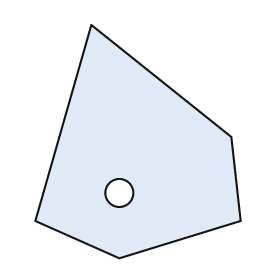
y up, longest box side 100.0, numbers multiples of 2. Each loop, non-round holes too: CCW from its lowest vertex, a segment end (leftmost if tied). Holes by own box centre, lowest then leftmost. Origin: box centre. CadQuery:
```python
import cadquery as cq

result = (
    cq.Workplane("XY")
    .moveTo(-8.0, -50.0)
    .lineTo(44.0, -34.0)
    .lineTo(40.0, 2.0)
    .lineTo(-20.0, 50.0)
    .lineTo(-44.0, -34.0)
    .close()
    .moveTo(-8.0, -22.0)
    .circle(6.0)
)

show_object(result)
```